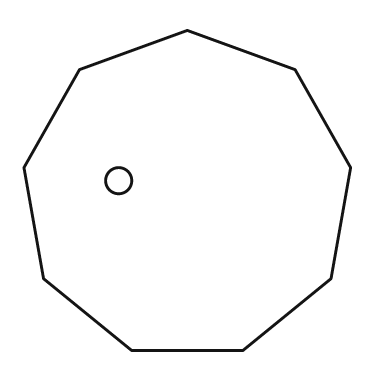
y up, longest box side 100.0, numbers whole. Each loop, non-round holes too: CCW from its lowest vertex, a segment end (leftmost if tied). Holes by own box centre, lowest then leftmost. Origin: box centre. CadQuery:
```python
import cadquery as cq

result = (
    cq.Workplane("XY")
    .moveTo(-17.0, -49.0)
    .lineTo(17.0, -49.0)
    .lineTo(44.0, -27.0)
    .lineTo(50.0, 7.0)
    .lineTo(33.0, 37.0)
    .lineTo(0.0, 49.0)
    .lineTo(-33.0, 37.0)
    .lineTo(-50.0, 7.0)
    .lineTo(-44.0, -27.0)
    .close()
    .moveTo(-21.0, 3.0)
    .circle(4.0)
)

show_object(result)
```